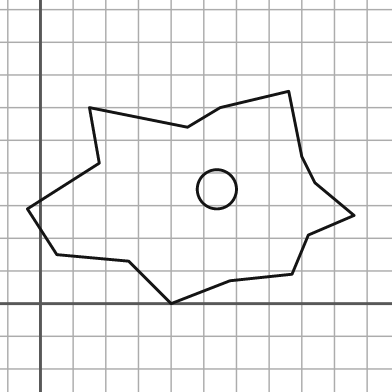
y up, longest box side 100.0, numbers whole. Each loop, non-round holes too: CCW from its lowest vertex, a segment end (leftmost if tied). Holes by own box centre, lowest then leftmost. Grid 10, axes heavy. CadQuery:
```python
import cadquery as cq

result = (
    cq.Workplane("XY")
    .moveTo(40.0, 0.0)
    .lineTo(58.0, 7.0)
    .lineTo(77.0, 9.0)
    .lineTo(82.0, 21.0)
    .lineTo(96.0, 27.0)
    .lineTo(84.0, 37.0)
    .lineTo(80.0, 45.0)
    .lineTo(76.0, 65.0)
    .lineTo(55.0, 60.0)
    .lineTo(45.0, 54.0)
    .lineTo(15.0, 60.0)
    .lineTo(18.0, 43.0)
    .lineTo(-4.0, 29.0)
    .lineTo(5.0, 15.0)
    .lineTo(27.0, 13.0)
    .close()
    .moveTo(54.0, 35.0)
    .circle(6.0)
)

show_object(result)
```